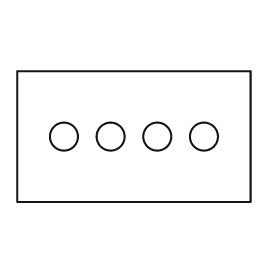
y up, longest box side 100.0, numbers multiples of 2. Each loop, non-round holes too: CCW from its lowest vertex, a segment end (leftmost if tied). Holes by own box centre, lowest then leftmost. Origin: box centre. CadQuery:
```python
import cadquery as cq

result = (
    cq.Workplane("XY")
    .moveTo(-50.0, -28.0)
    .lineTo(50.0, -28.0)
    .lineTo(50.0, 28.0)
    .lineTo(-50.0, 28.0)
    .close()
    .moveTo(-30.0, 0.0)
    .circle(6.0)
    .moveTo(-10.0, 0.0)
    .circle(6.0)
    .moveTo(10.0, 0.0)
    .circle(6.0)
    .moveTo(30.0, 0.0)
    .circle(6.0)
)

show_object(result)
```